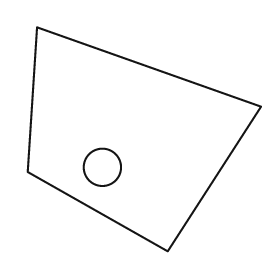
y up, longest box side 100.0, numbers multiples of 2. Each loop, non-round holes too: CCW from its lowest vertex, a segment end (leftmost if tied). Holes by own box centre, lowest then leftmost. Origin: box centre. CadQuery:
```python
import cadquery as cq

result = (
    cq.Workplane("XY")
    .moveTo(10.0, -48.0)
    .lineTo(50.0, 14.0)
    .lineTo(-46.0, 48.0)
    .lineTo(-50.0, -14.0)
    .close()
    .moveTo(-18.0, -12.0)
    .circle(8.0)
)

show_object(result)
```